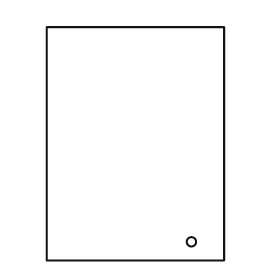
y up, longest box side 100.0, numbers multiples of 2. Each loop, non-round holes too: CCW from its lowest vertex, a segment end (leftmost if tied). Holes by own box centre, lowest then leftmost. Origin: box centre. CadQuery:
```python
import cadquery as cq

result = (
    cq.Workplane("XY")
    .moveTo(-38.0, -50.0)
    .lineTo(38.0, -50.0)
    .lineTo(38.0, 50.0)
    .lineTo(-38.0, 50.0)
    .close()
    .moveTo(24.0, -42.0)
    .circle(2.0)
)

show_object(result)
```